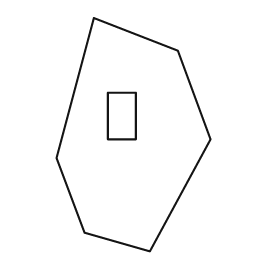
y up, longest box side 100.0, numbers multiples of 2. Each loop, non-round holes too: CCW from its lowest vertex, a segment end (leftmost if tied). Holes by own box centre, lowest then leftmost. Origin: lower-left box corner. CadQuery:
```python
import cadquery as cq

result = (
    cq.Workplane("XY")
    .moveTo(40.0, 0.0)
    .lineTo(66.0, 48.0)
    .lineTo(52.0, 86.0)
    .lineTo(16.0, 100.0)
    .lineTo(0.0, 40.0)
    .lineTo(12.0, 8.0)
    .close()
    .moveTo(22.0, 48.0)
    .lineTo(34.0, 48.0)
    .lineTo(34.0, 68.0)
    .lineTo(22.0, 68.0)
    .close()
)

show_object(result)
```